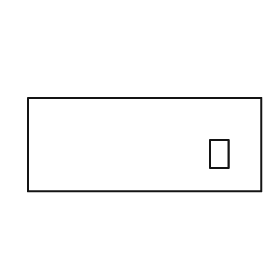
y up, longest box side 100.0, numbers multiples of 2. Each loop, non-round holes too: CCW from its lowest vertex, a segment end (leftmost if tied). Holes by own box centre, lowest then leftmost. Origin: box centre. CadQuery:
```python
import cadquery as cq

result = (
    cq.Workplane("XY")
    .moveTo(-50.0, -20.0)
    .lineTo(50.0, -20.0)
    .lineTo(50.0, 20.0)
    .lineTo(-50.0, 20.0)
    .close()
    .moveTo(28.0, -10.0)
    .lineTo(36.0, -10.0)
    .lineTo(36.0, 2.0)
    .lineTo(28.0, 2.0)
    .close()
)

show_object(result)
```